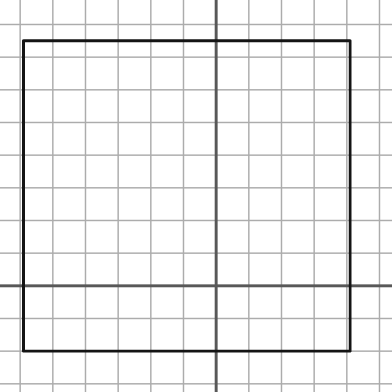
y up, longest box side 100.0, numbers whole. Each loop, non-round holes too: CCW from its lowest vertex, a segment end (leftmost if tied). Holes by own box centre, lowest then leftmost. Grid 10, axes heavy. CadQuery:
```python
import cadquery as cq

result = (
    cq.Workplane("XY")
    .moveTo(-59.0, -20.0)
    .lineTo(41.0, -20.0)
    .lineTo(41.0, 75.0)
    .lineTo(-59.0, 75.0)
    .close()
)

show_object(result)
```